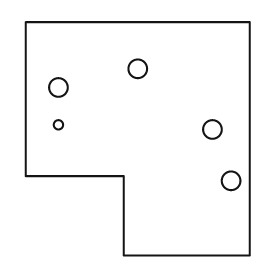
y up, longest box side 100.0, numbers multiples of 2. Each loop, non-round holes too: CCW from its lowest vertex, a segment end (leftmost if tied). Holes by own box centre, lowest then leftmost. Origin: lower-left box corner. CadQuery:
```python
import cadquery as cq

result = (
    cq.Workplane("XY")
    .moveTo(42.0, 0.0)
    .lineTo(96.0, 0.0)
    .lineTo(96.0, 100.0)
    .lineTo(0.0, 100.0)
    .lineTo(0.0, 34.0)
    .lineTo(42.0, 34.0)
    .close()
    .moveTo(88.0, 32.0)
    .circle(4.0)
    .moveTo(80.0, 54.0)
    .circle(4.0)
    .moveTo(14.0, 56.0)
    .circle(2.0)
    .moveTo(14.0, 72.0)
    .circle(4.0)
    .moveTo(48.0, 80.0)
    .circle(4.0)
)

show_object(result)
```